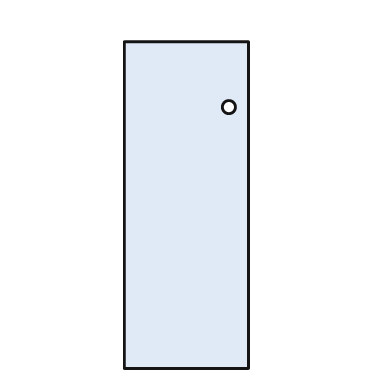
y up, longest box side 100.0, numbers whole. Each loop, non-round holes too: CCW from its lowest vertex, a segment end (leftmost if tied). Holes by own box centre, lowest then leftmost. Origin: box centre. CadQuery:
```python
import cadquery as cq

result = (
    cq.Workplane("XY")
    .moveTo(-19.0, -50.0)
    .lineTo(19.0, -50.0)
    .lineTo(19.0, 50.0)
    .lineTo(-19.0, 50.0)
    .close()
    .moveTo(13.0, 30.0)
    .circle(2.0)
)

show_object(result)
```